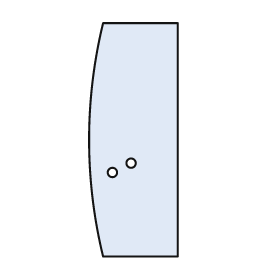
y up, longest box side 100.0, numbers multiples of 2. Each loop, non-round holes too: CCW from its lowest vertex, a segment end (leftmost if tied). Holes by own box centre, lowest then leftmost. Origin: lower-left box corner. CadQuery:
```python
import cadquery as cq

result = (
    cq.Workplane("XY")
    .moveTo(6.0, 0.0)
    .lineTo(38.0, 0.0)
    .lineTo(38.0, 100.0)
    .lineTo(6.0, 100.0)
    .threePointArc((0.0, 50.0), (6.0, 0.0))
    .close()
    .moveTo(10.0, 36.0)
    .circle(2.0)
    .moveTo(18.0, 40.0)
    .circle(2.0)
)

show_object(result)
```